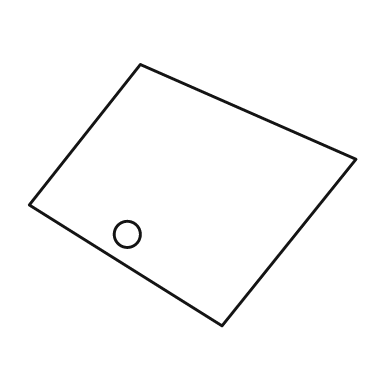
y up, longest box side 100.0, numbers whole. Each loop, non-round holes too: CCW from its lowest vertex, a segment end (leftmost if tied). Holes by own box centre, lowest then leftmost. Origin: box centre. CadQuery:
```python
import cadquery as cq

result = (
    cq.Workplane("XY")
    .moveTo(9.0, -40.0)
    .lineTo(50.0, 11.0)
    .lineTo(-16.0, 40.0)
    .lineTo(-50.0, -3.0)
    .close()
    .moveTo(-20.0, -12.0)
    .circle(4.0)
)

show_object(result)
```